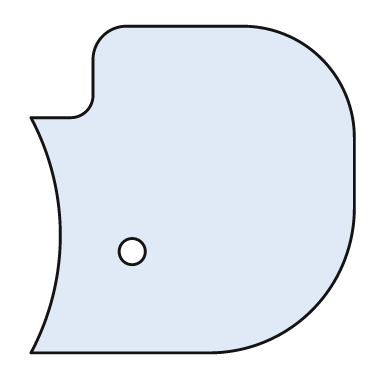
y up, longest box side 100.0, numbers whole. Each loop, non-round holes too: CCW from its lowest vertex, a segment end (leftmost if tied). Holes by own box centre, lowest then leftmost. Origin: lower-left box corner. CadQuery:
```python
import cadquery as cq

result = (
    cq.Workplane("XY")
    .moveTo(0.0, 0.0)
    .lineTo(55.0, 0.0)
    .threePointArc((86.0, 13.0), (99.0, 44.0))
    .lineTo(99.0, 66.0)
    .threePointArc((89.0, 90.0), (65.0, 100.0))
    .lineTo(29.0, 100.0)
    .threePointArc((22.0, 97.0), (19.0, 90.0))
    .lineTo(19.0, 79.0)
    .threePointArc((17.0, 74.0), (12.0, 72.0))
    .lineTo(0.0, 72.0)
    .threePointArc((9.0, 36.0), (0.0, 0.0))
    .close()
    .moveTo(31.0, 31.0)
    .circle(4.0)
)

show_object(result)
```